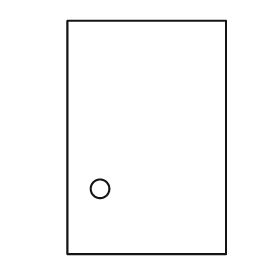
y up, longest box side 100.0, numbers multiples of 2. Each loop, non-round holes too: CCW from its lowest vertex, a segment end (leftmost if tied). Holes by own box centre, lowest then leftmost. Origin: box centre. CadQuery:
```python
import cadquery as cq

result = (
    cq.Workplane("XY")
    .moveTo(-34.0, -50.0)
    .lineTo(34.0, -50.0)
    .lineTo(34.0, 50.0)
    .lineTo(-34.0, 50.0)
    .close()
    .moveTo(-20.0, -22.0)
    .circle(4.0)
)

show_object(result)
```